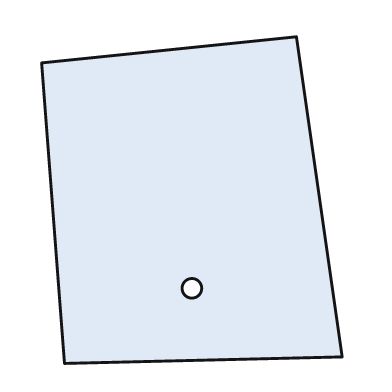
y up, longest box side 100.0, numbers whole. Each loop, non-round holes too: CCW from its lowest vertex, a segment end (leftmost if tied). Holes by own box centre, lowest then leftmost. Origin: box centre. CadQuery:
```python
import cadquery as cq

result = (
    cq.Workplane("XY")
    .moveTo(-39.0, -50.0)
    .lineTo(46.0, -48.0)
    .lineTo(32.0, 50.0)
    .lineTo(-46.0, 42.0)
    .close()
    .moveTo(0.0, -27.0)
    .circle(3.0)
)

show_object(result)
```